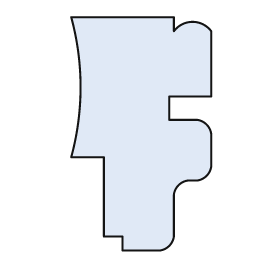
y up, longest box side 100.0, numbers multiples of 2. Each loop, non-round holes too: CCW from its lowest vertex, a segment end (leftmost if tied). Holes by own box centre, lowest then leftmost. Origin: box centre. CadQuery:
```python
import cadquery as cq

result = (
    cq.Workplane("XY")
    .moveTo(-8.0, -50.0)
    .lineTo(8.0, -50.0)
    .threePointArc((12.0, -48.0), (14.0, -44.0))
    .lineTo(14.0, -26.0)
    .threePointArc((16.0, -22.0), (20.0, -20.0))
    .lineTo(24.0, -20.0)
    .threePointArc((28.0, -18.0), (30.0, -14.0))
    .lineTo(30.0, 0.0)
    .threePointArc((28.0, 4.0), (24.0, 6.0))
    .lineTo(12.0, 6.0)
    .lineTo(12.0, 16.0)
    .lineTo(30.0, 16.0)
    .lineTo(30.0, 44.0)
    .threePointArc((22.0, 48.0), (14.0, 44.0))
    .lineTo(14.0, 50.0)
    .lineTo(-30.0, 50.0)
    .threePointArc((-26.0, 20.0), (-30.0, -10.0))
    .lineTo(-16.0, -10.0)
    .lineTo(-16.0, -44.0)
    .lineTo(-8.0, -44.0)
    .close()
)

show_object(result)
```